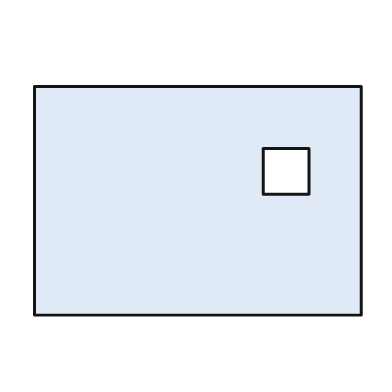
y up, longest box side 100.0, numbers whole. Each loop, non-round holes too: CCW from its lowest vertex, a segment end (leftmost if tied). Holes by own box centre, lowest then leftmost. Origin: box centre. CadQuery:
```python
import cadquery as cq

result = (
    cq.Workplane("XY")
    .moveTo(-50.0, -35.0)
    .lineTo(50.0, -35.0)
    .lineTo(50.0, 35.0)
    .lineTo(-50.0, 35.0)
    .close()
    .moveTo(20.0, 2.0)
    .lineTo(34.0, 2.0)
    .lineTo(34.0, 16.0)
    .lineTo(20.0, 16.0)
    .close()
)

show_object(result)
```